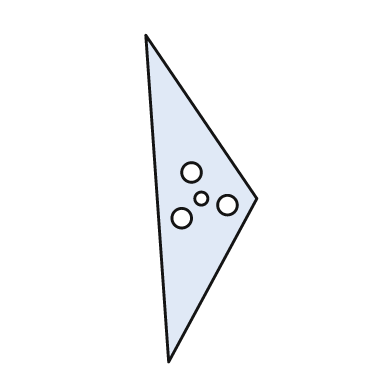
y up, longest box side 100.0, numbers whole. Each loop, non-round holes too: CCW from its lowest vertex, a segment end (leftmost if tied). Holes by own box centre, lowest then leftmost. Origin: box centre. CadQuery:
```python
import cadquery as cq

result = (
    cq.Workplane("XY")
    .moveTo(-10.0, -50.0)
    .lineTo(17.0, 0.0)
    .lineTo(-17.0, 50.0)
    .close()
    .moveTo(-6.0, -6.0)
    .circle(3.0)
    .moveTo(8.0, -2.0)
    .circle(3.0)
    .moveTo(0.0, 0.0)
    .circle(2.0)
    .moveTo(-3.0, 8.0)
    .circle(3.0)
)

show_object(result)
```